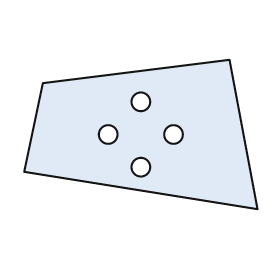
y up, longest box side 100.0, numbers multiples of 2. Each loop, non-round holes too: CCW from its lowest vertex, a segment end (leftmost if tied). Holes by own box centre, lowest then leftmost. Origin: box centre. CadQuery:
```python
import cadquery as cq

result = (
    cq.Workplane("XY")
    .moveTo(50.0, -32.0)
    .lineTo(38.0, 32.0)
    .lineTo(-42.0, 22.0)
    .lineTo(-50.0, -16.0)
    .close()
    .moveTo(0.0, -14.0)
    .circle(4.0)
    .moveTo(-14.0, 0.0)
    .circle(4.0)
    .moveTo(14.0, 0.0)
    .circle(4.0)
    .moveTo(0.0, 14.0)
    .circle(4.0)
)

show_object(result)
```